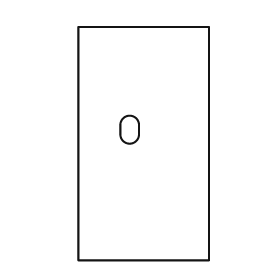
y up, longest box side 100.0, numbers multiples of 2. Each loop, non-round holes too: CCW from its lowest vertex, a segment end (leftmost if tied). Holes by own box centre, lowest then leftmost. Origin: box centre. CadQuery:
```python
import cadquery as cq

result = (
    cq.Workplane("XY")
    .moveTo(-28.0, -50.0)
    .lineTo(28.0, -50.0)
    .lineTo(28.0, 50.0)
    .lineTo(-28.0, 50.0)
    .close()
    .moveTo(-10.0, 4.0)
    .threePointArc((-6.0, 0.0), (-2.0, 4.0))
    .lineTo(-2.0, 8.0)
    .threePointArc((-6.0, 12.0), (-10.0, 8.0))
    .close()
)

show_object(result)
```